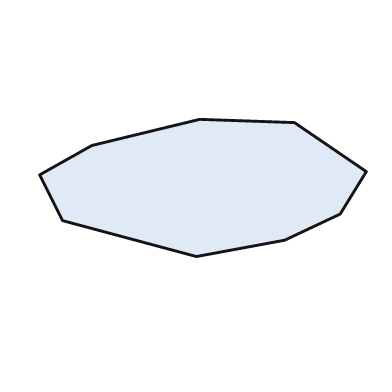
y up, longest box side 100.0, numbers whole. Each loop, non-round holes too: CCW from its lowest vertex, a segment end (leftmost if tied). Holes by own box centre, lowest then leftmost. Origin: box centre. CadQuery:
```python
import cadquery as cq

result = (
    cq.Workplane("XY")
    .moveTo(-2.0, -21.0)
    .lineTo(25.0, -16.0)
    .lineTo(42.0, -8.0)
    .lineTo(50.0, 5.0)
    .lineTo(28.0, 20.0)
    .lineTo(-1.0, 21.0)
    .lineTo(-34.0, 13.0)
    .lineTo(-50.0, 4.0)
    .lineTo(-43.0, -10.0)
    .close()
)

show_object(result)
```